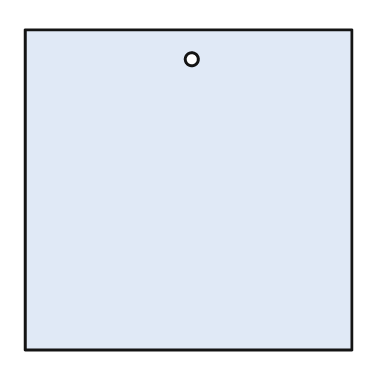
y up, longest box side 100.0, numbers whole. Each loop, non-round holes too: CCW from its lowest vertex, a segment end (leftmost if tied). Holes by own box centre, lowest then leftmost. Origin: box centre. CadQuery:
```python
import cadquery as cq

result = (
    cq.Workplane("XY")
    .moveTo(-50.0, -49.0)
    .lineTo(50.0, -49.0)
    .lineTo(50.0, 49.0)
    .lineTo(-50.0, 49.0)
    .close()
    .moveTo(1.0, 40.0)
    .circle(2.0)
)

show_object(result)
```